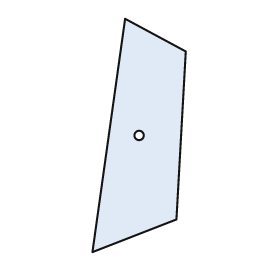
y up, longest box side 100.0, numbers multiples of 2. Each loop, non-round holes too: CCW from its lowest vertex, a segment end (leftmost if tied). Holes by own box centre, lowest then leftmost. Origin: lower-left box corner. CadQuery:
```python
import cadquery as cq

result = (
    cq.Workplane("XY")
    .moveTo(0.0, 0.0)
    .lineTo(36.0, 14.0)
    .lineTo(40.0, 86.0)
    .lineTo(14.0, 100.0)
    .close()
    .moveTo(20.0, 50.0)
    .circle(2.0)
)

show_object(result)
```